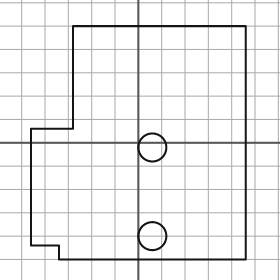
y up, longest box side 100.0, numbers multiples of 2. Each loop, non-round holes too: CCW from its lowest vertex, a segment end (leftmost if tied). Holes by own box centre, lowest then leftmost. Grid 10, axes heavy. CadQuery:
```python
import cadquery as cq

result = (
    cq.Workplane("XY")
    .moveTo(-34.0, -50.0)
    .lineTo(46.0, -50.0)
    .lineTo(46.0, 50.0)
    .lineTo(-28.0, 50.0)
    .lineTo(-28.0, 6.0)
    .lineTo(-46.0, 6.0)
    .lineTo(-46.0, -44.0)
    .lineTo(-34.0, -44.0)
    .close()
    .moveTo(6.0, -40.0)
    .circle(6.0)
    .moveTo(6.0, -2.0)
    .circle(6.0)
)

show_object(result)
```